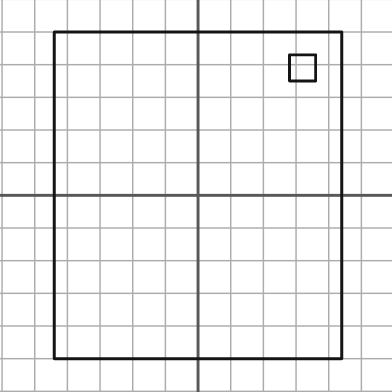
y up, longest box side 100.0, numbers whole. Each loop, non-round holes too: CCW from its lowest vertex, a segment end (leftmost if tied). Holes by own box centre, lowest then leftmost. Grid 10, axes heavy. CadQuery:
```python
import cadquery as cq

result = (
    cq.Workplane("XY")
    .moveTo(-44.0, -50.0)
    .lineTo(44.0, -50.0)
    .lineTo(44.0, 50.0)
    .lineTo(-44.0, 50.0)
    .close()
    .moveTo(28.0, 35.0)
    .lineTo(36.0, 35.0)
    .lineTo(36.0, 43.0)
    .lineTo(28.0, 43.0)
    .close()
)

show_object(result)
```